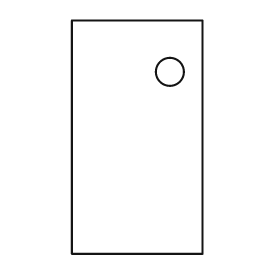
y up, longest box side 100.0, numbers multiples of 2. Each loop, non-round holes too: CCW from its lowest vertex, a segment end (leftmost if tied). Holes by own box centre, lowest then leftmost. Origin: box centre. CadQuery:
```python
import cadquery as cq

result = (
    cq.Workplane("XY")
    .moveTo(-28.0, -50.0)
    .lineTo(28.0, -50.0)
    .lineTo(28.0, 50.0)
    .lineTo(-28.0, 50.0)
    .close()
    .moveTo(14.0, 28.0)
    .circle(6.0)
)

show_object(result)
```